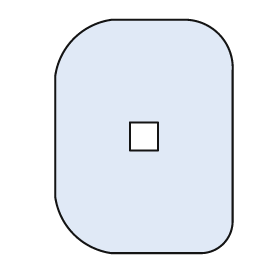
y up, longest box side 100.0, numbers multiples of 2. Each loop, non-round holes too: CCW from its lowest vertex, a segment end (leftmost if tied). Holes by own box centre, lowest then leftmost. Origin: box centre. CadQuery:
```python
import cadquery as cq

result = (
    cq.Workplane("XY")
    .moveTo(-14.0, -50.0)
    .lineTo(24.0, -50.0)
    .threePointArc((34.0, -46.0), (38.0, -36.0))
    .lineTo(38.0, 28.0)
    .threePointArc((32.0, 44.0), (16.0, 50.0))
    .lineTo(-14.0, 50.0)
    .threePointArc((-30.0, 42.0), (-38.0, 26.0))
    .lineTo(-38.0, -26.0)
    .threePointArc((-30.0, -42.0), (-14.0, -50.0))
    .close()
    .moveTo(-6.0, -6.0)
    .lineTo(6.0, -6.0)
    .lineTo(6.0, 6.0)
    .lineTo(-6.0, 6.0)
    .close()
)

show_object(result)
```